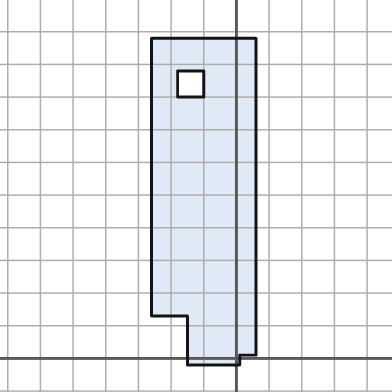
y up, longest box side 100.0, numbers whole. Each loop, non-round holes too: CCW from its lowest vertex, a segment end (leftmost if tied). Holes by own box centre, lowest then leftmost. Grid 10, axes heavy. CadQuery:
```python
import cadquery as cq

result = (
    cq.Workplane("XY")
    .moveTo(-15.0, -2.0)
    .lineTo(1.0, -2.0)
    .lineTo(1.0, 1.0)
    .lineTo(6.0, 1.0)
    .lineTo(6.0, 98.0)
    .lineTo(-26.0, 98.0)
    .lineTo(-26.0, 13.0)
    .lineTo(-15.0, 13.0)
    .close()
    .moveTo(-18.0, 80.0)
    .lineTo(-10.0, 80.0)
    .lineTo(-10.0, 88.0)
    .lineTo(-18.0, 88.0)
    .close()
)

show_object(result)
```